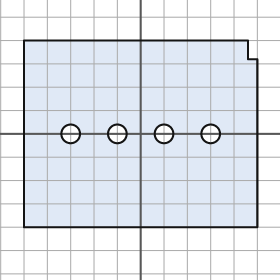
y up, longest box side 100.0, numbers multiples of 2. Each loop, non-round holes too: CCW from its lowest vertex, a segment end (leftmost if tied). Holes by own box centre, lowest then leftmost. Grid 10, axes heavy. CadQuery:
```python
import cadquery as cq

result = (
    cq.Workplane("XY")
    .moveTo(-50.0, -40.0)
    .lineTo(50.0, -40.0)
    .lineTo(50.0, 32.0)
    .lineTo(46.0, 32.0)
    .lineTo(46.0, 40.0)
    .lineTo(-50.0, 40.0)
    .close()
    .moveTo(-30.0, 0.0)
    .circle(4.0)
    .moveTo(-10.0, 0.0)
    .circle(4.0)
    .moveTo(10.0, 0.0)
    .circle(4.0)
    .moveTo(30.0, 0.0)
    .circle(4.0)
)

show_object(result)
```